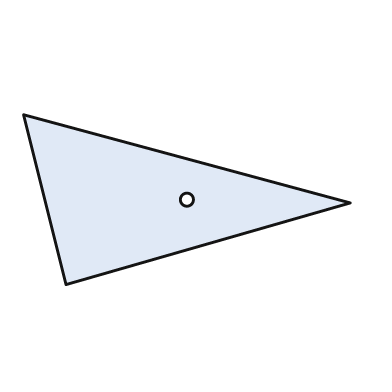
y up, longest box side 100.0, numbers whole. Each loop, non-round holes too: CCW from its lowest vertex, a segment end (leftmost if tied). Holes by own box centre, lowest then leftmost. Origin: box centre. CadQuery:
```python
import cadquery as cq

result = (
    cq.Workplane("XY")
    .moveTo(-37.0, -26.0)
    .lineTo(50.0, -1.0)
    .lineTo(-50.0, 26.0)
    .close()
    .moveTo(0.0, 0.0)
    .circle(2.0)
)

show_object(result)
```